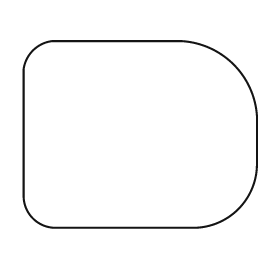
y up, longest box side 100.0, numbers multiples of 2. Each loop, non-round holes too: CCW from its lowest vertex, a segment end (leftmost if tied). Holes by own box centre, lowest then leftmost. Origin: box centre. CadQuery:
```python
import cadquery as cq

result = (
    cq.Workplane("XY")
    .moveTo(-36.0, -40.0)
    .lineTo(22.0, -40.0)
    .threePointArc((42.0, -32.0), (50.0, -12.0))
    .lineTo(50.0, 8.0)
    .threePointArc((40.0, 30.0), (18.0, 40.0))
    .lineTo(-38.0, 40.0)
    .threePointArc((-46.0, 36.0), (-50.0, 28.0))
    .lineTo(-50.0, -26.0)
    .threePointArc((-46.0, -36.0), (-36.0, -40.0))
    .close()
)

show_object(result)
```